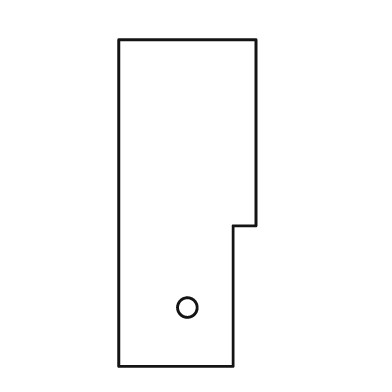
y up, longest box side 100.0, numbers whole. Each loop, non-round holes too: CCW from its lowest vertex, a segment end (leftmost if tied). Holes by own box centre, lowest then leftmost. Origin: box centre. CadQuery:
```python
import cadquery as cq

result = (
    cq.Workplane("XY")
    .moveTo(-21.0, -50.0)
    .lineTo(14.0, -50.0)
    .lineTo(14.0, -7.0)
    .lineTo(21.0, -7.0)
    .lineTo(21.0, 50.0)
    .lineTo(-21.0, 50.0)
    .close()
    .moveTo(0.0, -32.0)
    .circle(3.0)
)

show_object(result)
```